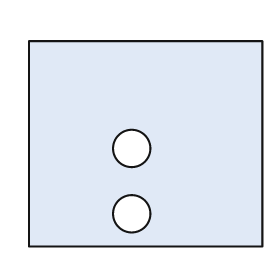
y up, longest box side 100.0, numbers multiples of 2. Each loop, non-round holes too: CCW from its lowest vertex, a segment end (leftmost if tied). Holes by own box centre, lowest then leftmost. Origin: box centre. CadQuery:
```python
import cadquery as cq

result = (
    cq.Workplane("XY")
    .moveTo(-50.0, -44.0)
    .lineTo(50.0, -44.0)
    .lineTo(50.0, 44.0)
    .lineTo(-50.0, 44.0)
    .close()
    .moveTo(-6.0, -30.0)
    .circle(8.0)
    .moveTo(-6.0, -2.0)
    .circle(8.0)
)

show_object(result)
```